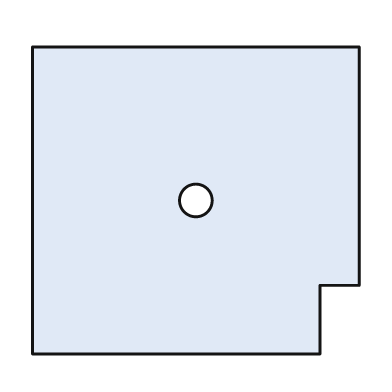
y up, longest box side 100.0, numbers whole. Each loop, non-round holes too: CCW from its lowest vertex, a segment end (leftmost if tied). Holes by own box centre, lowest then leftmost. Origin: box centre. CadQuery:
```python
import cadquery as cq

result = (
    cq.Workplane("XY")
    .moveTo(-50.0, -47.0)
    .lineTo(38.0, -47.0)
    .lineTo(38.0, -26.0)
    .lineTo(50.0, -26.0)
    .lineTo(50.0, 47.0)
    .lineTo(-50.0, 47.0)
    .close()
    .moveTo(0.0, 0.0)
    .circle(5.0)
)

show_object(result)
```